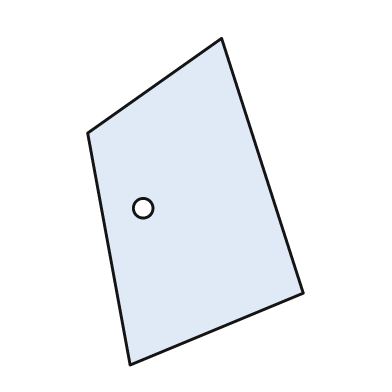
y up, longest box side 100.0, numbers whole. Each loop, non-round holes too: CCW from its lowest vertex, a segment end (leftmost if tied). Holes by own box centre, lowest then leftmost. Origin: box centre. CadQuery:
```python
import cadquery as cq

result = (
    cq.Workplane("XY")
    .moveTo(-20.0, -50.0)
    .lineTo(33.0, -28.0)
    .lineTo(8.0, 50.0)
    .lineTo(-33.0, 21.0)
    .close()
    .moveTo(-16.0, -2.0)
    .circle(3.0)
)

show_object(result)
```